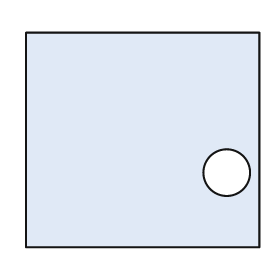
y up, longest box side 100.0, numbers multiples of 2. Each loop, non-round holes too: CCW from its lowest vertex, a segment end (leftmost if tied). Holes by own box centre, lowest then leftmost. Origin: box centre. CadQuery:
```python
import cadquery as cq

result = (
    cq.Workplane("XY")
    .moveTo(-50.0, -46.0)
    .lineTo(50.0, -46.0)
    .lineTo(50.0, 46.0)
    .lineTo(-50.0, 46.0)
    .close()
    .moveTo(36.0, -14.0)
    .circle(10.0)
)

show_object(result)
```